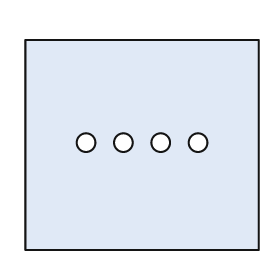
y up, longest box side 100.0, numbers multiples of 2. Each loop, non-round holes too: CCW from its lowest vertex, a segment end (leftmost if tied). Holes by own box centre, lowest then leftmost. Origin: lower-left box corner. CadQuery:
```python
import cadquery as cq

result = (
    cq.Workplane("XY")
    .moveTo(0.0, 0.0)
    .lineTo(100.0, 0.0)
    .lineTo(100.0, 90.0)
    .lineTo(0.0, 90.0)
    .close()
    .moveTo(26.0, 46.0)
    .circle(4.0)
    .moveTo(42.0, 46.0)
    .circle(4.0)
    .moveTo(58.0, 46.0)
    .circle(4.0)
    .moveTo(74.0, 46.0)
    .circle(4.0)
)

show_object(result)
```